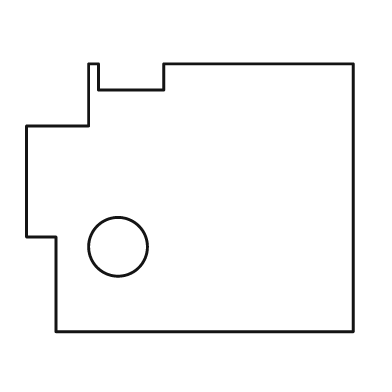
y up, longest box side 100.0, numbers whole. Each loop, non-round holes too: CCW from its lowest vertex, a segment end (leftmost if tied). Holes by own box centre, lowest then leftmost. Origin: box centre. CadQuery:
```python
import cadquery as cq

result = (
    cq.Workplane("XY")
    .moveTo(-41.0, -41.0)
    .lineTo(50.0, -41.0)
    .lineTo(50.0, 41.0)
    .lineTo(-8.0, 41.0)
    .lineTo(-8.0, 33.0)
    .lineTo(-28.0, 33.0)
    .lineTo(-28.0, 41.0)
    .lineTo(-31.0, 41.0)
    .lineTo(-31.0, 22.0)
    .lineTo(-50.0, 22.0)
    .lineTo(-50.0, -12.0)
    .lineTo(-41.0, -12.0)
    .close()
    .moveTo(-22.0, -15.0)
    .circle(9.0)
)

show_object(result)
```